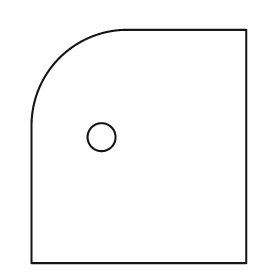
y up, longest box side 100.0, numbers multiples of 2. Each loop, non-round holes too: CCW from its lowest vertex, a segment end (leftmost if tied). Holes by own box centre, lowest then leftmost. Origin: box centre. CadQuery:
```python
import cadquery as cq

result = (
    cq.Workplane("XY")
    .moveTo(-46.0, -50.0)
    .lineTo(46.0, -50.0)
    .lineTo(46.0, 50.0)
    .lineTo(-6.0, 50.0)
    .threePointArc((-34.0, 38.0), (-46.0, 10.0))
    .close()
    .moveTo(-16.0, 4.0)
    .circle(6.0)
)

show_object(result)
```